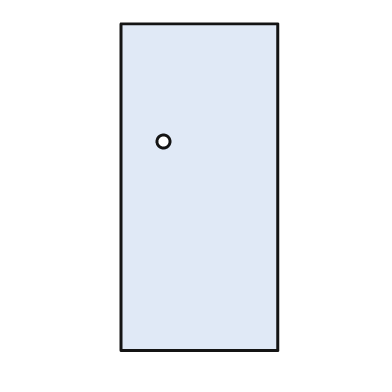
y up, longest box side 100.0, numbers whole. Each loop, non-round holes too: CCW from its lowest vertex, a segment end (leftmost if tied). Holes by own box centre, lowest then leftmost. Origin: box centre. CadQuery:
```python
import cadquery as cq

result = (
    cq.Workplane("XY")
    .moveTo(-24.0, -50.0)
    .lineTo(24.0, -50.0)
    .lineTo(24.0, 50.0)
    .lineTo(-24.0, 50.0)
    .close()
    .moveTo(-11.0, 14.0)
    .circle(2.0)
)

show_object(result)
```